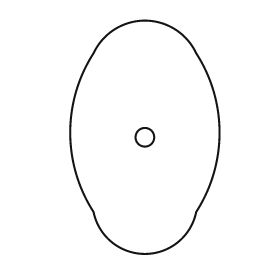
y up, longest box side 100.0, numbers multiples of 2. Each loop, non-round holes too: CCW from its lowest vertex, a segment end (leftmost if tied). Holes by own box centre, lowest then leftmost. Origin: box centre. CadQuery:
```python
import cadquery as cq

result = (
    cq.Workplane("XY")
    .moveTo(-22.0, -32.0)
    .threePointArc((0.0, -50.0), (22.0, -32.0))
    .threePointArc((32.0, 2.0), (22.0, 36.0))
    .threePointArc((0.0, 50.0), (-22.0, 36.0))
    .threePointArc((-32.0, 2.0), (-22.0, -32.0))
    .close()
    .moveTo(0.0, 0.0)
    .circle(4.0)
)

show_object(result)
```